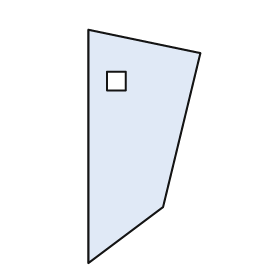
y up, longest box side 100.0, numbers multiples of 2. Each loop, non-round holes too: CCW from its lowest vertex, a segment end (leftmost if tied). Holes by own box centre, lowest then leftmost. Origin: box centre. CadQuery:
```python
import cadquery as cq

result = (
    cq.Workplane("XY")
    .moveTo(-24.0, -50.0)
    .lineTo(8.0, -26.0)
    .lineTo(24.0, 40.0)
    .lineTo(-24.0, 50.0)
    .close()
    .moveTo(-16.0, 24.0)
    .lineTo(-8.0, 24.0)
    .lineTo(-8.0, 32.0)
    .lineTo(-16.0, 32.0)
    .close()
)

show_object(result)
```